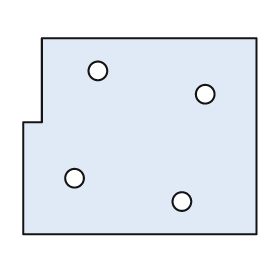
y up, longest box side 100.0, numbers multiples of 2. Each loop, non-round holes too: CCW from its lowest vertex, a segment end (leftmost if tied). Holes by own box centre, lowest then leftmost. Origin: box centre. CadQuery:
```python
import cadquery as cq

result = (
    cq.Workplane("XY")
    .moveTo(-50.0, -42.0)
    .lineTo(50.0, -42.0)
    .lineTo(50.0, 42.0)
    .lineTo(-42.0, 42.0)
    .lineTo(-42.0, 6.0)
    .lineTo(-50.0, 6.0)
    .close()
    .moveTo(18.0, -28.0)
    .circle(4.0)
    .moveTo(-28.0, -18.0)
    .circle(4.0)
    .moveTo(28.0, 18.0)
    .circle(4.0)
    .moveTo(-18.0, 28.0)
    .circle(4.0)
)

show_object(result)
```